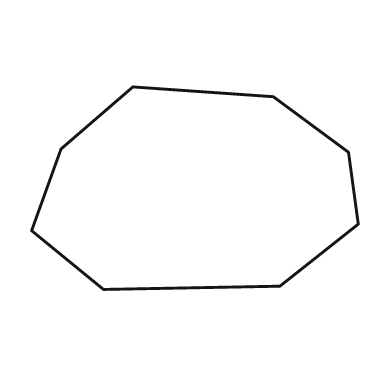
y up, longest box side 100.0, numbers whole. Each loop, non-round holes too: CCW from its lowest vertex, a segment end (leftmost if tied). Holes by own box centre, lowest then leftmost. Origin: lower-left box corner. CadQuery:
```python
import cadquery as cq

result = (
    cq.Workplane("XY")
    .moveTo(22.0, 0.0)
    .lineTo(76.0, 1.0)
    .lineTo(100.0, 20.0)
    .lineTo(97.0, 42.0)
    .lineTo(74.0, 59.0)
    .lineTo(31.0, 62.0)
    .lineTo(9.0, 43.0)
    .lineTo(0.0, 18.0)
    .close()
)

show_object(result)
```